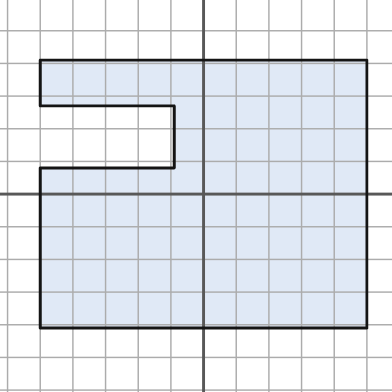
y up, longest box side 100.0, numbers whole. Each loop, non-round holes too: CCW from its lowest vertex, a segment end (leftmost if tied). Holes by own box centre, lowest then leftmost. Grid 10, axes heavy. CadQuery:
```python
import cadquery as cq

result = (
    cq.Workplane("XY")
    .moveTo(-50.0, -41.0)
    .lineTo(50.0, -41.0)
    .lineTo(50.0, 41.0)
    .lineTo(-50.0, 41.0)
    .lineTo(-50.0, 27.0)
    .lineTo(-9.0, 27.0)
    .lineTo(-9.0, 8.0)
    .lineTo(-50.0, 8.0)
    .close()
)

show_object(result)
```